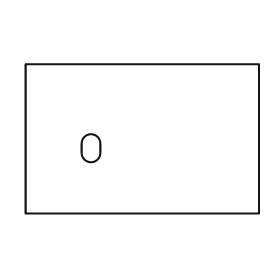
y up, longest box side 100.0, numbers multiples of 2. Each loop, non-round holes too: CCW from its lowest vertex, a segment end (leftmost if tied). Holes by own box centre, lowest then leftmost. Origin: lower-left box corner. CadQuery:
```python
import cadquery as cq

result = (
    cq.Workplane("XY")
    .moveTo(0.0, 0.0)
    .lineTo(100.0, 0.0)
    .lineTo(100.0, 64.0)
    .lineTo(0.0, 64.0)
    .close()
    .moveTo(24.0, 26.0)
    .threePointArc((28.0, 22.0), (32.0, 26.0))
    .lineTo(32.0, 30.0)
    .threePointArc((28.0, 34.0), (24.0, 30.0))
    .close()
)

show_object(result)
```